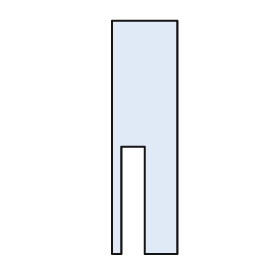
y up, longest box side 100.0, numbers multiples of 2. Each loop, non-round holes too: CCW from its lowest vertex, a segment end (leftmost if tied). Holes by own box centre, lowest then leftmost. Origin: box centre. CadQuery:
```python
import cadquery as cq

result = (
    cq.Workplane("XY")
    .moveTo(-14.0, -50.0)
    .lineTo(-10.0, -50.0)
    .lineTo(-10.0, -4.0)
    .lineTo(0.0, -4.0)
    .lineTo(0.0, -50.0)
    .lineTo(14.0, -50.0)
    .lineTo(14.0, 50.0)
    .lineTo(-14.0, 50.0)
    .close()
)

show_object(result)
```